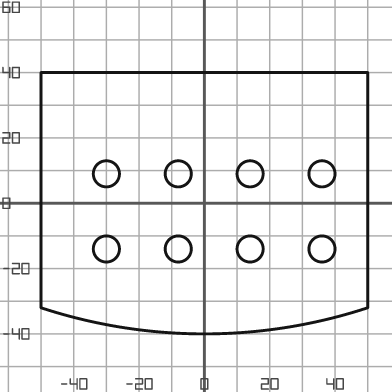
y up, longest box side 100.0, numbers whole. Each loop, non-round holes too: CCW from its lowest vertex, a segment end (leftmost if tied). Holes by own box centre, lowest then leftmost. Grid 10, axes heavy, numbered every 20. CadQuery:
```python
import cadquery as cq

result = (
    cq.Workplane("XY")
    .moveTo(-50.0, -32.0)
    .threePointArc((0.0, -40.0), (50.0, -32.0))
    .lineTo(50.0, 40.0)
    .lineTo(-50.0, 40.0)
    .close()
    .moveTo(-30.0, -14.0)
    .circle(4.0)
    .moveTo(-8.0, -14.0)
    .circle(4.0)
    .moveTo(14.0, -14.0)
    .circle(4.0)
    .moveTo(36.0, -14.0)
    .circle(4.0)
    .moveTo(-30.0, 9.0)
    .circle(4.0)
    .moveTo(-8.0, 9.0)
    .circle(4.0)
    .moveTo(14.0, 9.0)
    .circle(4.0)
    .moveTo(36.0, 9.0)
    .circle(4.0)
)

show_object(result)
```